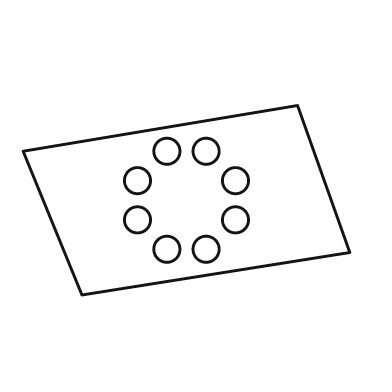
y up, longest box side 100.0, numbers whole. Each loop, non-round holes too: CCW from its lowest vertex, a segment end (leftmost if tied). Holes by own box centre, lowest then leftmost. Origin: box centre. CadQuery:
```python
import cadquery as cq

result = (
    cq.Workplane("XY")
    .moveTo(-32.0, -29.0)
    .lineTo(50.0, -16.0)
    .lineTo(34.0, 29.0)
    .lineTo(-50.0, 15.0)
    .close()
    .moveTo(-6.0, -15.0)
    .circle(4.0)
    .moveTo(6.0, -15.0)
    .circle(4.0)
    .moveTo(-15.0, -6.0)
    .circle(4.0)
    .moveTo(15.0, -6.0)
    .circle(4.0)
    .moveTo(-15.0, 6.0)
    .circle(4.0)
    .moveTo(15.0, 6.0)
    .circle(4.0)
    .moveTo(-6.0, 15.0)
    .circle(4.0)
    .moveTo(6.0, 15.0)
    .circle(4.0)
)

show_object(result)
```